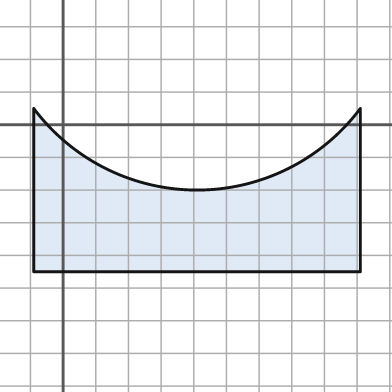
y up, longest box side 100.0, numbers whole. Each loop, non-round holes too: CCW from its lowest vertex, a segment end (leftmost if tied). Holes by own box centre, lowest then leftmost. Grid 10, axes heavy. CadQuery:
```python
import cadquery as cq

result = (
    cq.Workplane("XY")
    .moveTo(-9.0, -45.0)
    .lineTo(91.0, -45.0)
    .lineTo(91.0, 5.0)
    .threePointArc((41.0, -20.0), (-9.0, 5.0))
    .close()
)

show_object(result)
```